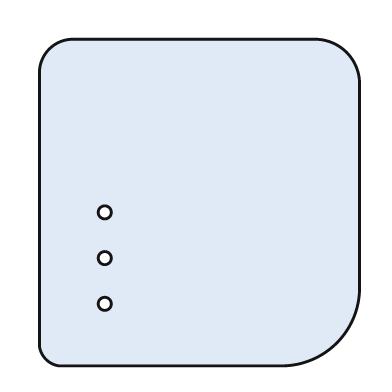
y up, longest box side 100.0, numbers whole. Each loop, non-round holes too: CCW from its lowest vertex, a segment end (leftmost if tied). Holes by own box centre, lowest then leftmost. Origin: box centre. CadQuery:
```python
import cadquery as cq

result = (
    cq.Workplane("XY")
    .moveTo(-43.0, -50.0)
    .lineTo(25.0, -50.0)
    .threePointArc((42.0, -43.0), (49.0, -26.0))
    .lineTo(49.0, 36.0)
    .threePointArc((45.0, 46.0), (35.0, 50.0))
    .lineTo(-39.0, 50.0)
    .threePointArc((-46.0, 47.0), (-49.0, 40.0))
    .lineTo(-49.0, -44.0)
    .threePointArc((-47.0, -48.0), (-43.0, -50.0))
    .close()
    .moveTo(-29.0, -31.0)
    .circle(2.0)
    .moveTo(-29.0, -17.0)
    .circle(2.0)
    .moveTo(-29.0, -3.0)
    .circle(2.0)
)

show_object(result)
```